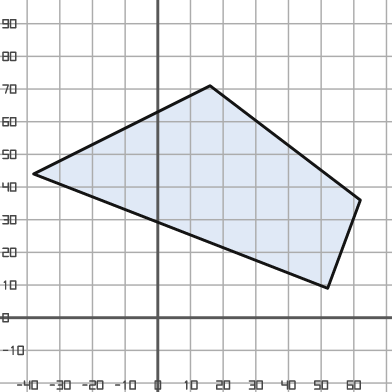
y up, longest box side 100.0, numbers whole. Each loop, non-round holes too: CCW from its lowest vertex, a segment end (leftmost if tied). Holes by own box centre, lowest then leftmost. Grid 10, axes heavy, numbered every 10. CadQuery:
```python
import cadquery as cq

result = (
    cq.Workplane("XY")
    .moveTo(52.0, 9.0)
    .lineTo(62.0, 36.0)
    .lineTo(16.0, 71.0)
    .lineTo(-38.0, 44.0)
    .close()
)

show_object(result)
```